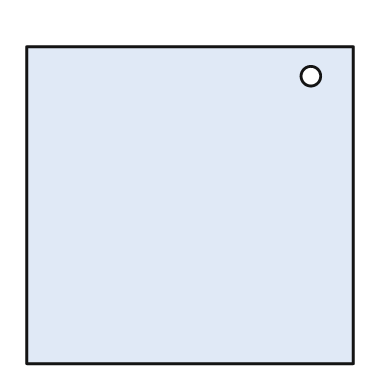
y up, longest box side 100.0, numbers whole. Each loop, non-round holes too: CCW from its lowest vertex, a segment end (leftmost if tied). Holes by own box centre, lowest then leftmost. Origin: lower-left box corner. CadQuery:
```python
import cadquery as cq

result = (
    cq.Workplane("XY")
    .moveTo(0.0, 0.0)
    .lineTo(100.0, 0.0)
    .lineTo(100.0, 97.0)
    .lineTo(0.0, 97.0)
    .close()
    .moveTo(87.0, 88.0)
    .circle(3.0)
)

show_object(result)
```